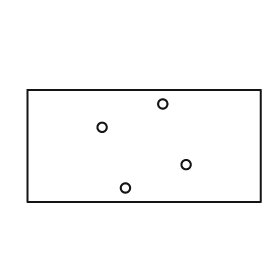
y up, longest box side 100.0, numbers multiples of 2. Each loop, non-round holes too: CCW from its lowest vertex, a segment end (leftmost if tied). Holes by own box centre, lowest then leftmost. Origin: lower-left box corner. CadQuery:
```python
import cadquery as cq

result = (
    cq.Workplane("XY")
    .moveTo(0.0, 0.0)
    .lineTo(100.0, 0.0)
    .lineTo(100.0, 48.0)
    .lineTo(0.0, 48.0)
    .close()
    .moveTo(42.0, 6.0)
    .circle(2.0)
    .moveTo(68.0, 16.0)
    .circle(2.0)
    .moveTo(32.0, 32.0)
    .circle(2.0)
    .moveTo(58.0, 42.0)
    .circle(2.0)
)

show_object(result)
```